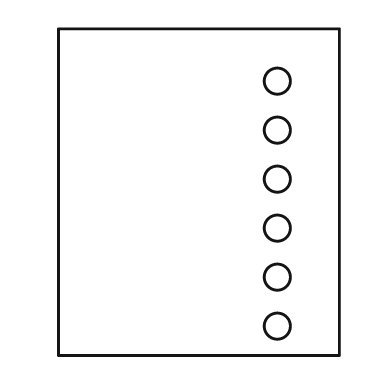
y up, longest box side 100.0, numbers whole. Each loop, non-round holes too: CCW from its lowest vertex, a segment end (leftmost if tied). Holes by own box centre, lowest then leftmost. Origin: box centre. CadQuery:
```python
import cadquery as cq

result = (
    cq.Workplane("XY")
    .moveTo(-43.0, -50.0)
    .lineTo(43.0, -50.0)
    .lineTo(43.0, 50.0)
    .lineTo(-43.0, 50.0)
    .close()
    .moveTo(24.0, -41.0)
    .circle(4.0)
    .moveTo(24.0, -26.0)
    .circle(4.0)
    .moveTo(24.0, -11.0)
    .circle(4.0)
    .moveTo(24.0, 4.0)
    .circle(4.0)
    .moveTo(24.0, 19.0)
    .circle(4.0)
    .moveTo(24.0, 34.0)
    .circle(4.0)
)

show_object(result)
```